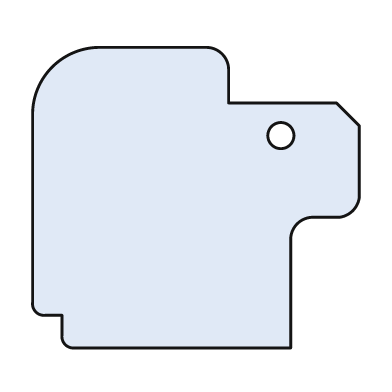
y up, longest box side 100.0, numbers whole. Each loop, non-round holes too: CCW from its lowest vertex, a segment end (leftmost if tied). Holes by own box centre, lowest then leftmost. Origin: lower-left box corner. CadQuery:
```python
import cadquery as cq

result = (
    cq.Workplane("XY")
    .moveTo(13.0, 0.0)
    .lineTo(79.0, 0.0)
    .lineTo(79.0, 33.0)
    .threePointArc((81.0, 38.0), (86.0, 40.0))
    .lineTo(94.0, 40.0)
    .threePointArc((98.0, 42.0), (100.0, 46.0))
    .lineTo(100.0, 68.0)
    .lineTo(93.0, 75.0)
    .lineTo(60.0, 75.0)
    .lineTo(60.0, 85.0)
    .threePointArc((58.0, 90.0), (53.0, 92.0))
    .lineTo(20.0, 92.0)
    .threePointArc((6.0, 86.0), (0.0, 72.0))
    .lineTo(0.0, 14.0)
    .threePointArc((1.0, 11.0), (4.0, 10.0))
    .lineTo(9.0, 10.0)
    .lineTo(9.0, 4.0)
    .threePointArc((10.0, 1.0), (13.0, 0.0))
    .close()
    .moveTo(76.0, 65.0)
    .circle(4.0)
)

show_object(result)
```